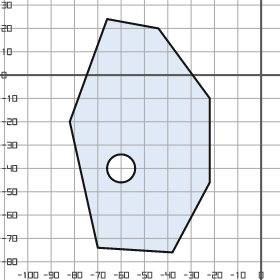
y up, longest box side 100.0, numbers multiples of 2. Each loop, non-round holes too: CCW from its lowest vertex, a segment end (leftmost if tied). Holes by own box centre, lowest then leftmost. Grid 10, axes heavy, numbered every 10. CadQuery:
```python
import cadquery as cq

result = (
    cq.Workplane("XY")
    .moveTo(-38.0, -76.0)
    .lineTo(-22.0, -46.0)
    .lineTo(-22.0, -10.0)
    .lineTo(-44.0, 20.0)
    .lineTo(-66.0, 24.0)
    .lineTo(-82.0, -20.0)
    .lineTo(-70.0, -74.0)
    .close()
    .moveTo(-60.0, -40.0)
    .circle(6.0)
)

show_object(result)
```